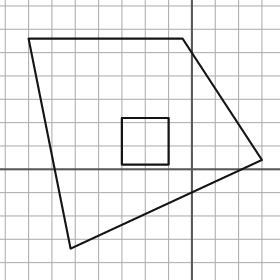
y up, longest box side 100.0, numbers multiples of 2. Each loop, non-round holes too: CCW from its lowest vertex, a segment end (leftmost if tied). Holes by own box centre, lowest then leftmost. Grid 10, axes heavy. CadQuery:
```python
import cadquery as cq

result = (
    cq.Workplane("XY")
    .moveTo(-52.0, -34.0)
    .lineTo(30.0, 4.0)
    .lineTo(-4.0, 56.0)
    .lineTo(-70.0, 56.0)
    .close()
    .moveTo(-30.0, 2.0)
    .lineTo(-10.0, 2.0)
    .lineTo(-10.0, 22.0)
    .lineTo(-30.0, 22.0)
    .close()
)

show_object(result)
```